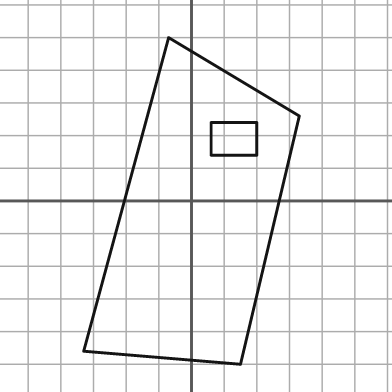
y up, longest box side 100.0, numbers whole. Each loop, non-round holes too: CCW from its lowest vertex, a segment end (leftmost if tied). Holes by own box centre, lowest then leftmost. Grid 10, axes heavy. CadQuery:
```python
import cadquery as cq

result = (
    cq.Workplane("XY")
    .moveTo(15.0, -50.0)
    .lineTo(33.0, 26.0)
    .lineTo(-7.0, 50.0)
    .lineTo(-33.0, -46.0)
    .close()
    .moveTo(6.0, 14.0)
    .lineTo(20.0, 14.0)
    .lineTo(20.0, 24.0)
    .lineTo(6.0, 24.0)
    .close()
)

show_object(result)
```